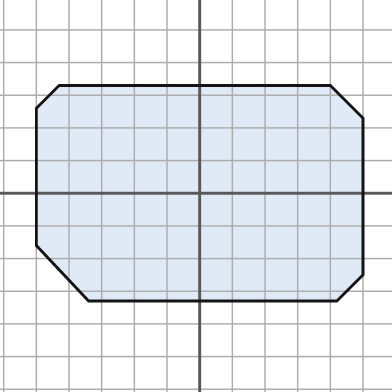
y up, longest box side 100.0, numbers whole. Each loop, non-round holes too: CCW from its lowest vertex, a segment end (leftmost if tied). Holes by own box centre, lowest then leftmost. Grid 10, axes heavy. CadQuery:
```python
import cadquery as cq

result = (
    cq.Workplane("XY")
    .moveTo(-34.0, -33.0)
    .lineTo(42.0, -33.0)
    .lineTo(50.0, -25.0)
    .lineTo(50.0, 23.0)
    .lineTo(40.0, 33.0)
    .lineTo(-43.0, 33.0)
    .lineTo(-50.0, 26.0)
    .lineTo(-50.0, -16.0)
    .close()
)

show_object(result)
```